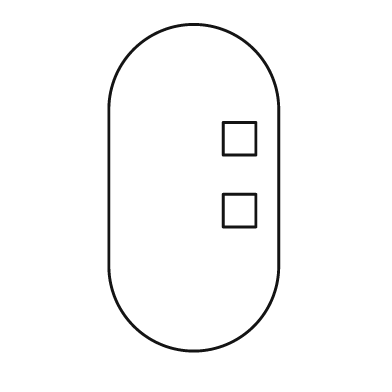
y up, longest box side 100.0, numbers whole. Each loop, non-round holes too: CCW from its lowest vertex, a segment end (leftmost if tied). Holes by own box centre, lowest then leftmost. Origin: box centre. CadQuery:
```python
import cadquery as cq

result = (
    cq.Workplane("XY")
    .moveTo(-26.0, -24.0)
    .threePointArc((0.0, -50.0), (26.0, -24.0))
    .lineTo(26.0, 24.0)
    .threePointArc((0.0, 50.0), (-26.0, 24.0))
    .close()
    .moveTo(9.0, -12.0)
    .lineTo(19.0, -12.0)
    .lineTo(19.0, -2.0)
    .lineTo(9.0, -2.0)
    .close()
    .moveTo(9.0, 10.0)
    .lineTo(19.0, 10.0)
    .lineTo(19.0, 20.0)
    .lineTo(9.0, 20.0)
    .close()
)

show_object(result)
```